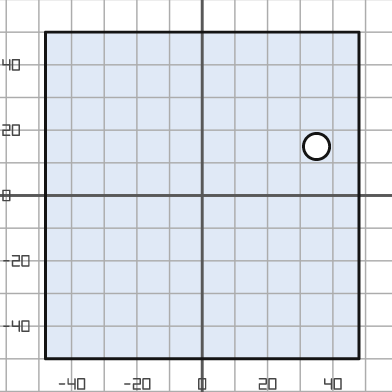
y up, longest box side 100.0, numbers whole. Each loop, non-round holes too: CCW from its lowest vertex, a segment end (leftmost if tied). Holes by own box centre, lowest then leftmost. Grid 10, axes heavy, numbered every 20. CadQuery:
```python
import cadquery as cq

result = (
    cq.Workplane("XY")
    .moveTo(-48.0, -50.0)
    .lineTo(48.0, -50.0)
    .lineTo(48.0, 50.0)
    .lineTo(-48.0, 50.0)
    .close()
    .moveTo(35.0, 15.0)
    .circle(4.0)
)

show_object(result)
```